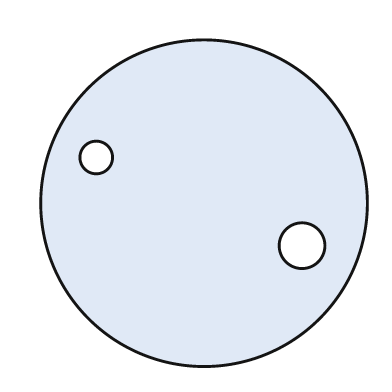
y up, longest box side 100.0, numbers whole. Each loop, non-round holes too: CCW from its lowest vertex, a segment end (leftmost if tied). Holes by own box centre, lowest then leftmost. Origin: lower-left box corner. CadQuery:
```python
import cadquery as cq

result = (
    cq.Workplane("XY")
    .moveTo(50.0, 50.0)
    .circle(50.0)
    .moveTo(80.0, 37.0)
    .circle(7.0)
    .moveTo(17.0, 64.0)
    .circle(5.0)
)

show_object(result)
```